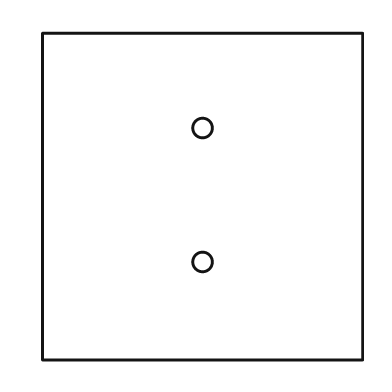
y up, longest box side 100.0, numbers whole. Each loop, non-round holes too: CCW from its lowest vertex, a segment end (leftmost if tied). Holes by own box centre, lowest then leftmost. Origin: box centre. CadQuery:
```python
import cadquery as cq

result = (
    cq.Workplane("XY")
    .moveTo(-49.0, -50.0)
    .lineTo(49.0, -50.0)
    .lineTo(49.0, 50.0)
    .lineTo(-49.0, 50.0)
    .close()
    .moveTo(0.0, -20.0)
    .circle(3.0)
    .moveTo(0.0, 21.0)
    .circle(3.0)
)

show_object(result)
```